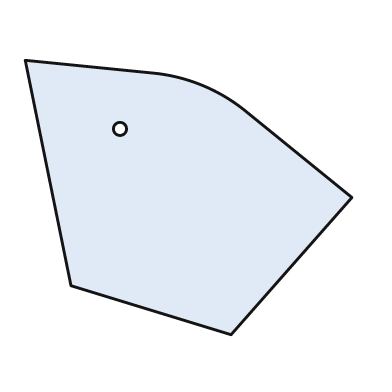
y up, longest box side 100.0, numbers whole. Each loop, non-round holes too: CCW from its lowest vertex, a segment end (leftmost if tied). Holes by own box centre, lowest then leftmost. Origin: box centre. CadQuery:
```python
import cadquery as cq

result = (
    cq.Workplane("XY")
    .moveTo(13.0, -42.0)
    .lineTo(50.0, 0.0)
    .lineTo(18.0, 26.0)
    .threePointArc((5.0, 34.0), (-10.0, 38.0))
    .lineTo(-50.0, 42.0)
    .lineTo(-36.0, -27.0)
    .close()
    .moveTo(-21.0, 21.0)
    .circle(2.0)
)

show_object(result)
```